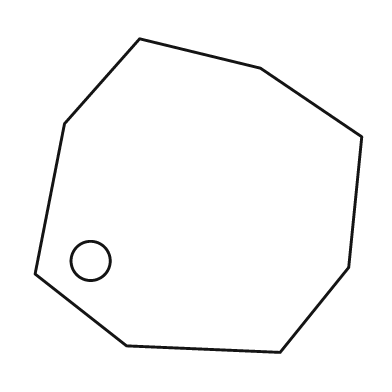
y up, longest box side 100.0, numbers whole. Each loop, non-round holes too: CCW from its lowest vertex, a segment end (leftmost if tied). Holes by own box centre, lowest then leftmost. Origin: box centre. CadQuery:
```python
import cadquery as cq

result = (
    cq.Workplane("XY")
    .moveTo(25.0, -48.0)
    .lineTo(46.0, -22.0)
    .lineTo(50.0, 18.0)
    .lineTo(19.0, 39.0)
    .lineTo(-18.0, 48.0)
    .lineTo(-41.0, 22.0)
    .lineTo(-50.0, -24.0)
    .lineTo(-22.0, -46.0)
    .close()
    .moveTo(-33.0, -20.0)
    .circle(6.0)
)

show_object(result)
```